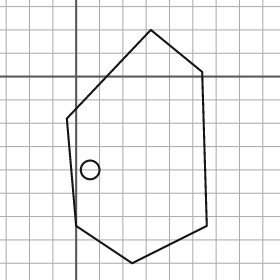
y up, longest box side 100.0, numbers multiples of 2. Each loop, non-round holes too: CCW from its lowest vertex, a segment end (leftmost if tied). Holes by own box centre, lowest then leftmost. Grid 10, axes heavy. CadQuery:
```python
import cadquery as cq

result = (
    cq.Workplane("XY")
    .moveTo(24.0, -80.0)
    .lineTo(56.0, -64.0)
    .lineTo(54.0, 2.0)
    .lineTo(32.0, 20.0)
    .lineTo(-4.0, -18.0)
    .lineTo(0.0, -64.0)
    .close()
    .moveTo(6.0, -40.0)
    .circle(4.0)
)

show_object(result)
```